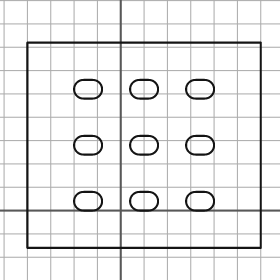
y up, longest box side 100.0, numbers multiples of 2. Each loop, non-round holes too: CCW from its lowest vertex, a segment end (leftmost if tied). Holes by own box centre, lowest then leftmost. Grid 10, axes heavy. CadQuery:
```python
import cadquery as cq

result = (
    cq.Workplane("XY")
    .moveTo(-40.0, -16.0)
    .lineTo(60.0, -16.0)
    .lineTo(60.0, 72.0)
    .lineTo(-40.0, 72.0)
    .close()
    .moveTo(-16.0, 0.0)
    .lineTo(-12.0, 0.0)
    .threePointArc((-8.0, 4.0), (-12.0, 8.0))
    .lineTo(-16.0, 8.0)
    .threePointArc((-20.0, 4.0), (-16.0, 0.0))
    .close()
    .moveTo(8.0, 0.0)
    .lineTo(12.0, 0.0)
    .threePointArc((16.0, 4.0), (12.0, 8.0))
    .lineTo(8.0, 8.0)
    .threePointArc((4.0, 4.0), (8.0, 0.0))
    .close()
    .moveTo(32.0, 0.0)
    .lineTo(36.0, 0.0)
    .threePointArc((40.0, 4.0), (36.0, 8.0))
    .lineTo(32.0, 8.0)
    .threePointArc((28.0, 4.0), (32.0, 0.0))
    .close()
    .moveTo(-16.0, 24.0)
    .lineTo(-12.0, 24.0)
    .threePointArc((-8.0, 28.0), (-12.0, 32.0))
    .lineTo(-16.0, 32.0)
    .threePointArc((-20.0, 28.0), (-16.0, 24.0))
    .close()
    .moveTo(8.0, 24.0)
    .lineTo(12.0, 24.0)
    .threePointArc((16.0, 28.0), (12.0, 32.0))
    .lineTo(8.0, 32.0)
    .threePointArc((4.0, 28.0), (8.0, 24.0))
    .close()
    .moveTo(32.0, 24.0)
    .lineTo(36.0, 24.0)
    .threePointArc((40.0, 28.0), (36.0, 32.0))
    .lineTo(32.0, 32.0)
    .threePointArc((28.0, 28.0), (32.0, 24.0))
    .close()
    .moveTo(-16.0, 48.0)
    .lineTo(-12.0, 48.0)
    .threePointArc((-8.0, 52.0), (-12.0, 56.0))
    .lineTo(-16.0, 56.0)
    .threePointArc((-20.0, 52.0), (-16.0, 48.0))
    .close()
    .moveTo(8.0, 48.0)
    .lineTo(12.0, 48.0)
    .threePointArc((16.0, 52.0), (12.0, 56.0))
    .lineTo(8.0, 56.0)
    .threePointArc((4.0, 52.0), (8.0, 48.0))
    .close()
    .moveTo(32.0, 48.0)
    .lineTo(36.0, 48.0)
    .threePointArc((40.0, 52.0), (36.0, 56.0))
    .lineTo(32.0, 56.0)
    .threePointArc((28.0, 52.0), (32.0, 48.0))
    .close()
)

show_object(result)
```